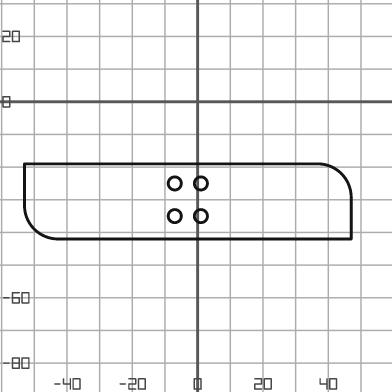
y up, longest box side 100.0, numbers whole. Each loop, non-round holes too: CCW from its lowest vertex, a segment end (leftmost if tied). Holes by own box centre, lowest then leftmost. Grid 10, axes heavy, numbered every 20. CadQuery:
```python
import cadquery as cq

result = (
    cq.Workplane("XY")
    .moveTo(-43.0, -42.0)
    .lineTo(47.0, -42.0)
    .lineTo(47.0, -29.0)
    .threePointArc((44.0, -22.0), (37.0, -19.0))
    .lineTo(-53.0, -19.0)
    .lineTo(-53.0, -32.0)
    .threePointArc((-50.0, -39.0), (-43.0, -42.0))
    .close()
    .moveTo(-7.0, -35.0)
    .circle(2.0)
    .moveTo(1.0, -35.0)
    .circle(2.0)
    .moveTo(-7.0, -25.0)
    .circle(2.0)
    .moveTo(1.0, -25.0)
    .circle(2.0)
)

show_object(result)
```